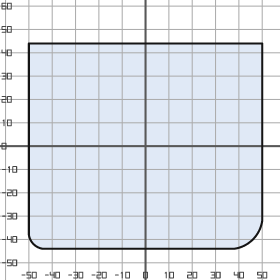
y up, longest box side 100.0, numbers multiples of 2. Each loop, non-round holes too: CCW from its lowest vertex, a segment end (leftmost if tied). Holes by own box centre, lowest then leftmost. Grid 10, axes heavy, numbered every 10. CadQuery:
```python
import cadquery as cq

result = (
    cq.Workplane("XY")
    .moveTo(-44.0, -44.0)
    .lineTo(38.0, -44.0)
    .threePointArc((46.0, -40.0), (50.0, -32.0))
    .lineTo(50.0, 44.0)
    .lineTo(-50.0, 44.0)
    .lineTo(-50.0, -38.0)
    .threePointArc((-48.0, -42.0), (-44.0, -44.0))
    .close()
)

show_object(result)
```